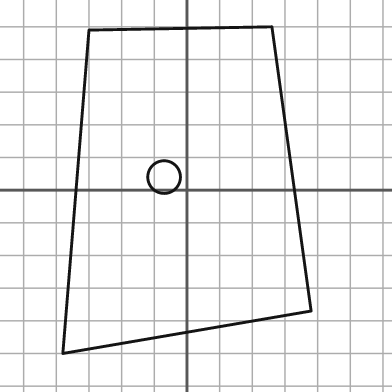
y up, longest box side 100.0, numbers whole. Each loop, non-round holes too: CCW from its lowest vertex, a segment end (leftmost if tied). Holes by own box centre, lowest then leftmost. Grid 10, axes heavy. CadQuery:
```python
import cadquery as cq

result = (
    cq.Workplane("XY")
    .moveTo(-38.0, -50.0)
    .lineTo(38.0, -37.0)
    .lineTo(26.0, 50.0)
    .lineTo(-30.0, 49.0)
    .close()
    .moveTo(-7.0, 4.0)
    .circle(5.0)
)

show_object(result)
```